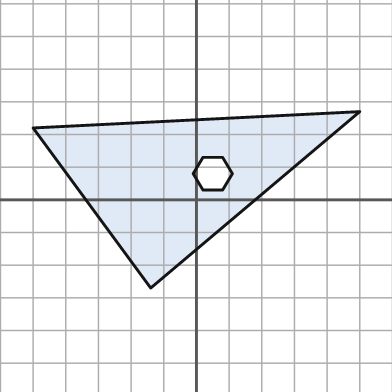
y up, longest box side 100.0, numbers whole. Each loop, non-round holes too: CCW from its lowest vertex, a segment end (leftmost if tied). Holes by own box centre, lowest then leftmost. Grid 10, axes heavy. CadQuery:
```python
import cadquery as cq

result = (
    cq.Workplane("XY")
    .moveTo(-14.0, -27.0)
    .lineTo(50.0, 27.0)
    .lineTo(-50.0, 22.0)
    .close()
    .moveTo(2.0, 3.0)
    .lineTo(8.0, 3.0)
    .lineTo(11.0, 8.0)
    .lineTo(8.0, 13.0)
    .lineTo(2.0, 13.0)
    .lineTo(-1.0, 8.0)
    .close()
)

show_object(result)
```